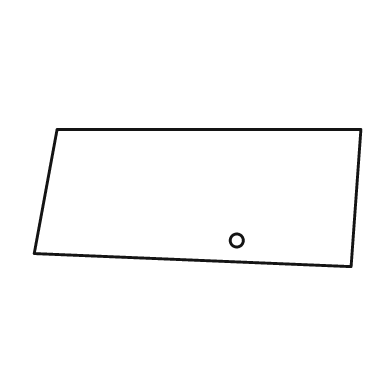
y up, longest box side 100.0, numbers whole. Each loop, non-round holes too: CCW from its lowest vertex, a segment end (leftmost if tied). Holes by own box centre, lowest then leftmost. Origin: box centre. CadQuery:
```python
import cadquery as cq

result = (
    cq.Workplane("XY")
    .moveTo(47.0, -21.0)
    .lineTo(50.0, 21.0)
    .lineTo(-43.0, 21.0)
    .lineTo(-50.0, -17.0)
    .close()
    .moveTo(12.0, -13.0)
    .circle(2.0)
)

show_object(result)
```